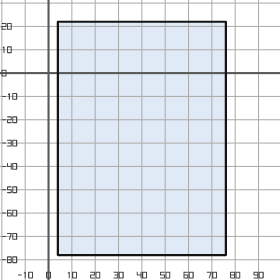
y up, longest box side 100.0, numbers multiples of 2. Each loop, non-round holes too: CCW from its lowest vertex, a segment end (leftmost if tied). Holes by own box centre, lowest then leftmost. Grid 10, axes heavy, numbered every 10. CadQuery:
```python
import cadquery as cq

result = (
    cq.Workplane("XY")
    .moveTo(4.0, -78.0)
    .lineTo(76.0, -78.0)
    .lineTo(76.0, 22.0)
    .lineTo(4.0, 22.0)
    .close()
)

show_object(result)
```